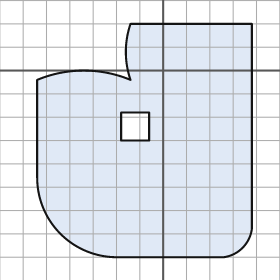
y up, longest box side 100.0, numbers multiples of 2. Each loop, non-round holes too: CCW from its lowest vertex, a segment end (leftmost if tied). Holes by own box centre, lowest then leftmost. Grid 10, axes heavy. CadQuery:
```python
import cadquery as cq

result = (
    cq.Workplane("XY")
    .moveTo(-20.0, -80.0)
    .lineTo(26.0, -80.0)
    .threePointArc((34.0, -76.0), (38.0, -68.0))
    .lineTo(38.0, 20.0)
    .lineTo(-14.0, 20.0)
    .threePointArc((-16.0, 8.0), (-14.0, -4.0))
    .threePointArc((-34.0, 0.0), (-54.0, -4.0))
    .lineTo(-54.0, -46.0)
    .threePointArc((-44.0, -70.0), (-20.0, -80.0))
    .close()
    .moveTo(-18.0, -30.0)
    .lineTo(-6.0, -30.0)
    .lineTo(-6.0, -18.0)
    .lineTo(-18.0, -18.0)
    .close()
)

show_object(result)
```